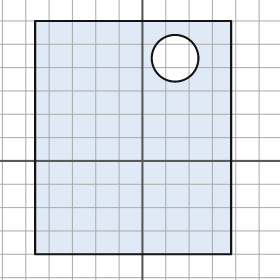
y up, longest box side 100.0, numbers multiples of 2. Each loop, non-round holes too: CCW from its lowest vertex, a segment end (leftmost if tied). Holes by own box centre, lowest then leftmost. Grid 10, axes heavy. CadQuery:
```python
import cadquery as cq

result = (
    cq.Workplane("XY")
    .moveTo(-46.0, -40.0)
    .lineTo(38.0, -40.0)
    .lineTo(38.0, 60.0)
    .lineTo(-46.0, 60.0)
    .close()
    .moveTo(14.0, 44.0)
    .circle(10.0)
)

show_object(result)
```